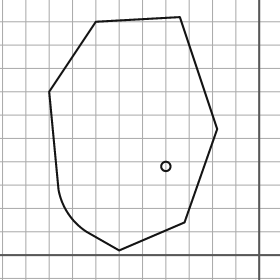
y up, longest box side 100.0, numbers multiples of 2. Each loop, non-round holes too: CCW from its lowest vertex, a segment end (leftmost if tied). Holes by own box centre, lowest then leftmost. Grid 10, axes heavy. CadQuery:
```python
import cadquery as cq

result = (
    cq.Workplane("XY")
    .moveTo(-60.0, 2.0)
    .lineTo(-32.0, 14.0)
    .lineTo(-18.0, 54.0)
    .lineTo(-34.0, 102.0)
    .lineTo(-70.0, 100.0)
    .lineTo(-90.0, 70.0)
    .lineTo(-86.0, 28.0)
    .threePointArc((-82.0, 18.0), (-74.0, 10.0))
    .close()
    .moveTo(-40.0, 38.0)
    .circle(2.0)
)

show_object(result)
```